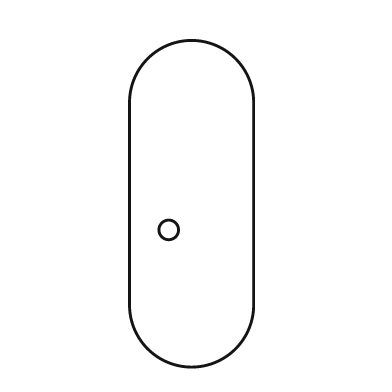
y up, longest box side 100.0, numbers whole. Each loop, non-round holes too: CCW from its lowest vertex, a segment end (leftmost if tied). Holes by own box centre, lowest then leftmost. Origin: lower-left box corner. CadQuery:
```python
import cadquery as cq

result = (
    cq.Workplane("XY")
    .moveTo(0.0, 19.0)
    .threePointArc((19.0, 0.0), (38.0, 19.0))
    .lineTo(38.0, 81.0)
    .threePointArc((19.0, 100.0), (0.0, 81.0))
    .close()
    .moveTo(12.0, 42.0)
    .circle(3.0)
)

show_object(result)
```